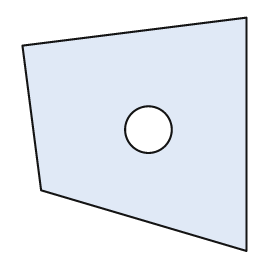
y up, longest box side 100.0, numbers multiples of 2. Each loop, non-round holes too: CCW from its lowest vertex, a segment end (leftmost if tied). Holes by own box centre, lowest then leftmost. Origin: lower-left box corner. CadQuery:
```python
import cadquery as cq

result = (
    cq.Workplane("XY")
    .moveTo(96.0, 0.0)
    .lineTo(96.0, 100.0)
    .lineTo(0.0, 88.0)
    .lineTo(8.0, 26.0)
    .close()
    .moveTo(54.0, 52.0)
    .circle(10.0)
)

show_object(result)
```